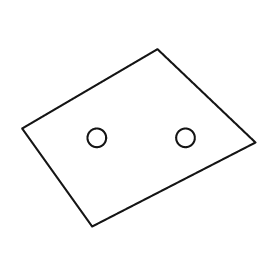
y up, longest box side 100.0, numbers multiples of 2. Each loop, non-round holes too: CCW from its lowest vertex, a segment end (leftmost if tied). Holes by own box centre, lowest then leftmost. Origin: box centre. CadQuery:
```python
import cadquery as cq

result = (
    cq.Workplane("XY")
    .moveTo(-20.0, -38.0)
    .lineTo(50.0, -2.0)
    .lineTo(8.0, 38.0)
    .lineTo(-50.0, 4.0)
    .close()
    .moveTo(-18.0, 0.0)
    .circle(4.0)
    .moveTo(20.0, 0.0)
    .circle(4.0)
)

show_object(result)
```